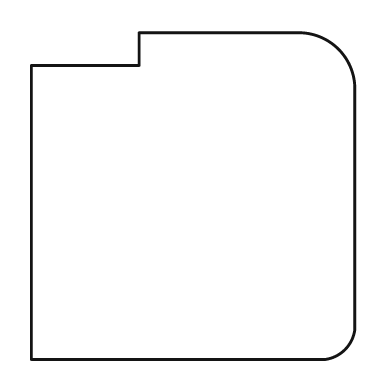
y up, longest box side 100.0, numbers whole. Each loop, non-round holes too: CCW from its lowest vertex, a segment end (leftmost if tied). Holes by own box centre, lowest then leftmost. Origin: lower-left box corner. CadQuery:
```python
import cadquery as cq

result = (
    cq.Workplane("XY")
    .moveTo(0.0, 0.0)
    .lineTo(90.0, 0.0)
    .threePointArc((96.0, 3.0), (99.0, 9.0))
    .lineTo(99.0, 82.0)
    .threePointArc((94.0, 95.0), (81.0, 100.0))
    .lineTo(33.0, 100.0)
    .lineTo(33.0, 90.0)
    .lineTo(0.0, 90.0)
    .close()
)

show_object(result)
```